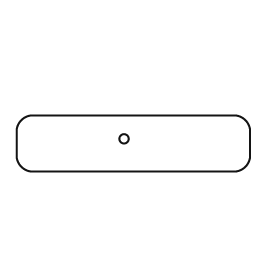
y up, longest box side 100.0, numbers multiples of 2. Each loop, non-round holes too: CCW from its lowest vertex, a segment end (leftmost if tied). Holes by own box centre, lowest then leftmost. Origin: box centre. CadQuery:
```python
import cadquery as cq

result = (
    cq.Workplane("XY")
    .moveTo(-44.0, -12.0)
    .lineTo(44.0, -12.0)
    .threePointArc((48.0, -10.0), (50.0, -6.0))
    .lineTo(50.0, 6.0)
    .threePointArc((48.0, 10.0), (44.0, 12.0))
    .lineTo(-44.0, 12.0)
    .threePointArc((-48.0, 10.0), (-50.0, 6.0))
    .lineTo(-50.0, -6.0)
    .threePointArc((-48.0, -10.0), (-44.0, -12.0))
    .close()
    .moveTo(-4.0, 2.0)
    .circle(2.0)
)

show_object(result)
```